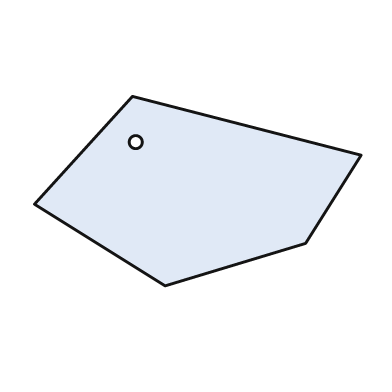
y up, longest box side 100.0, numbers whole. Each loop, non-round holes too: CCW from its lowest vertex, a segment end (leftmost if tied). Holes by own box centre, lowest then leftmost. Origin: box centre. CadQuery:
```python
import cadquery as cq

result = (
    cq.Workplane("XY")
    .moveTo(-10.0, -29.0)
    .lineTo(33.0, -16.0)
    .lineTo(50.0, 11.0)
    .lineTo(-20.0, 29.0)
    .lineTo(-50.0, -4.0)
    .close()
    .moveTo(-19.0, 15.0)
    .circle(2.0)
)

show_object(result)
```